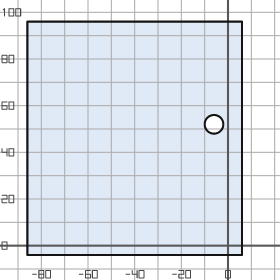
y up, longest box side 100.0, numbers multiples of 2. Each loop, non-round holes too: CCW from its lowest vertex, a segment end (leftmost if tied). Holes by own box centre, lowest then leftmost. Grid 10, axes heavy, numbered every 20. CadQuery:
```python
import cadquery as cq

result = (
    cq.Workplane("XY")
    .moveTo(-86.0, -4.0)
    .lineTo(6.0, -4.0)
    .lineTo(6.0, 96.0)
    .lineTo(-86.0, 96.0)
    .close()
    .moveTo(-6.0, 52.0)
    .circle(4.0)
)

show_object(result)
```